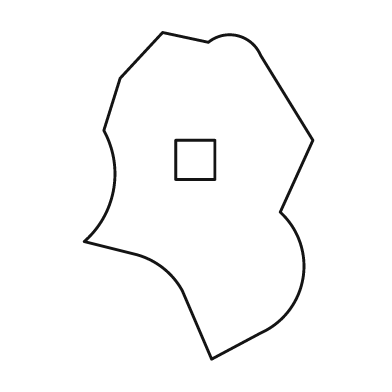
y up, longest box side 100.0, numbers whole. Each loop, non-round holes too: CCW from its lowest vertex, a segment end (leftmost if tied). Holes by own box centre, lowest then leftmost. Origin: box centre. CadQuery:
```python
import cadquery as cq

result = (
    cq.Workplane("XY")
    .moveTo(4.0, -50.0)
    .lineTo(19.0, -42.0)
    .threePointArc((32.0, -25.0), (25.0, -5.0))
    .lineTo(35.0, 17.0)
    .lineTo(19.0, 43.0)
    .threePointArc((12.0, 49.0), (3.0, 47.0))
    .lineTo(-11.0, 50.0)
    .lineTo(-24.0, 36.0)
    .lineTo(-29.0, 20.0)
    .threePointArc((-26.0, 2.0), (-35.0, -14.0))
    .lineTo(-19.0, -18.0)
    .threePointArc((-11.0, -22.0), (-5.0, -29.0))
    .close()
    .moveTo(-7.0, 5.0)
    .lineTo(5.0, 5.0)
    .lineTo(5.0, 17.0)
    .lineTo(-7.0, 17.0)
    .close()
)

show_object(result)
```